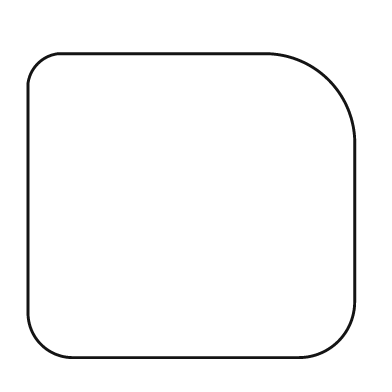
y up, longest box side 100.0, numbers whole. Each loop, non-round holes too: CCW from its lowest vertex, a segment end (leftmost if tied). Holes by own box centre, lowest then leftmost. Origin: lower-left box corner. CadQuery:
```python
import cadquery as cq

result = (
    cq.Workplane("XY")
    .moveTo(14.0, 0.0)
    .lineTo(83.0, 0.0)
    .threePointArc((95.0, 5.0), (100.0, 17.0))
    .lineTo(100.0, 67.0)
    .threePointArc((92.0, 85.0), (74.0, 93.0))
    .lineTo(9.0, 93.0)
    .threePointArc((3.0, 90.0), (0.0, 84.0))
    .lineTo(0.0, 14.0)
    .threePointArc((4.0, 4.0), (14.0, 0.0))
    .close()
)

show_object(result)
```